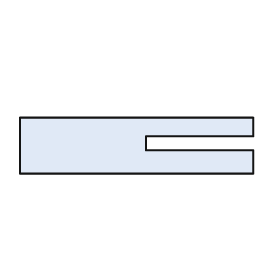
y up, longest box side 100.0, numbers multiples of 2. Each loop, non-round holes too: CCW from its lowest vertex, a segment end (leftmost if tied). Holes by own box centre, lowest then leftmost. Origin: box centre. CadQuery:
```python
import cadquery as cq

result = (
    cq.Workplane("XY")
    .moveTo(-50.0, -12.0)
    .lineTo(50.0, -12.0)
    .lineTo(50.0, -2.0)
    .lineTo(4.0, -2.0)
    .lineTo(4.0, 4.0)
    .lineTo(50.0, 4.0)
    .lineTo(50.0, 12.0)
    .lineTo(-50.0, 12.0)
    .close()
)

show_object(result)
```